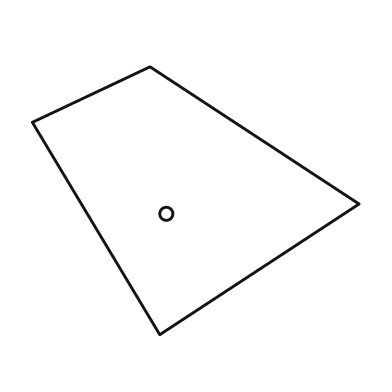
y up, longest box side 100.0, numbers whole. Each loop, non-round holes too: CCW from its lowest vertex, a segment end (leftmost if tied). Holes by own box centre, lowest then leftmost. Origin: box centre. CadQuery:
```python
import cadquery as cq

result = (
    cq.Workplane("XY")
    .moveTo(-11.0, -41.0)
    .lineTo(50.0, -1.0)
    .lineTo(-14.0, 41.0)
    .lineTo(-50.0, 24.0)
    .close()
    .moveTo(-9.0, -4.0)
    .circle(2.0)
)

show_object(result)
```